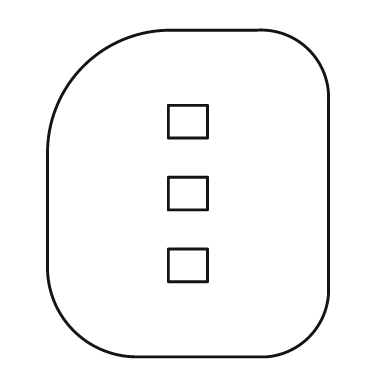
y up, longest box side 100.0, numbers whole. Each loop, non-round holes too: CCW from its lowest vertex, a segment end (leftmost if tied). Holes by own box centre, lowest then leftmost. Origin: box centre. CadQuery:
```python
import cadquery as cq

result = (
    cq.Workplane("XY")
    .moveTo(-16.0, -50.0)
    .lineTo(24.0, -50.0)
    .threePointArc((37.0, -44.0), (43.0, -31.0))
    .lineTo(43.0, 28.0)
    .threePointArc((37.0, 44.0), (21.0, 50.0))
    .lineTo(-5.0, 50.0)
    .threePointArc((-32.0, 39.0), (-43.0, 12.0))
    .lineTo(-43.0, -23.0)
    .threePointArc((-35.0, -42.0), (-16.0, -50.0))
    .close()
    .moveTo(-6.0, -27.0)
    .lineTo(6.0, -27.0)
    .lineTo(6.0, -17.0)
    .lineTo(-6.0, -17.0)
    .close()
    .moveTo(-6.0, -5.0)
    .lineTo(6.0, -5.0)
    .lineTo(6.0, 5.0)
    .lineTo(-6.0, 5.0)
    .close()
    .moveTo(-6.0, 17.0)
    .lineTo(6.0, 17.0)
    .lineTo(6.0, 27.0)
    .lineTo(-6.0, 27.0)
    .close()
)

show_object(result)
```